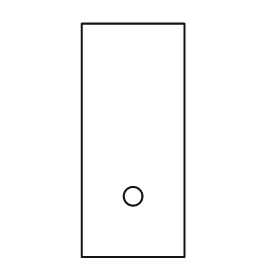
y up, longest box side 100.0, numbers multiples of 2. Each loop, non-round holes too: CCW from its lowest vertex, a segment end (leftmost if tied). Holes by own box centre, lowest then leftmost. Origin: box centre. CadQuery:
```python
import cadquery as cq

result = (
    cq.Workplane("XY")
    .moveTo(-22.0, -50.0)
    .lineTo(22.0, -50.0)
    .lineTo(22.0, 50.0)
    .lineTo(-22.0, 50.0)
    .close()
    .moveTo(0.0, -24.0)
    .circle(4.0)
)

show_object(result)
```